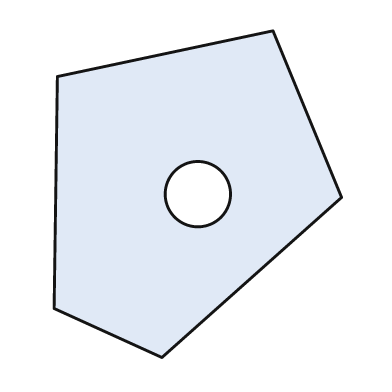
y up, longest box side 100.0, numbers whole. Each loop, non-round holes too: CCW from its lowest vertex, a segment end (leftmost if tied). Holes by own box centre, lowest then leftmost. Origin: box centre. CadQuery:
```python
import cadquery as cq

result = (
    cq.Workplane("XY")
    .moveTo(-11.0, -50.0)
    .lineTo(44.0, -1.0)
    .lineTo(23.0, 50.0)
    .lineTo(-43.0, 36.0)
    .lineTo(-44.0, -35.0)
    .close()
    .moveTo(0.0, 0.0)
    .circle(10.0)
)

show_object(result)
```